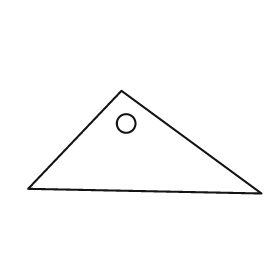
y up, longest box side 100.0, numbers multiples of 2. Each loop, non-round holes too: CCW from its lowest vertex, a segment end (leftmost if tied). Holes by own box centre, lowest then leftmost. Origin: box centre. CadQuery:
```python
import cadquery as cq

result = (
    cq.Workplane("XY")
    .moveTo(50.0, -22.0)
    .lineTo(-10.0, 22.0)
    .lineTo(-50.0, -20.0)
    .close()
    .moveTo(-8.0, 8.0)
    .circle(4.0)
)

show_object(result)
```